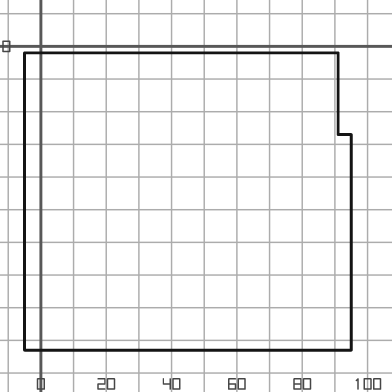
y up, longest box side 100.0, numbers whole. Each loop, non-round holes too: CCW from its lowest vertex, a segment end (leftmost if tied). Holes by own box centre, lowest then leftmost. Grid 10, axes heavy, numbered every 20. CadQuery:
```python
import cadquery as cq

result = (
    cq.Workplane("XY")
    .moveTo(-5.0, -93.0)
    .lineTo(95.0, -93.0)
    .lineTo(95.0, -27.0)
    .lineTo(91.0, -27.0)
    .lineTo(91.0, -2.0)
    .lineTo(-5.0, -2.0)
    .close()
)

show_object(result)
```